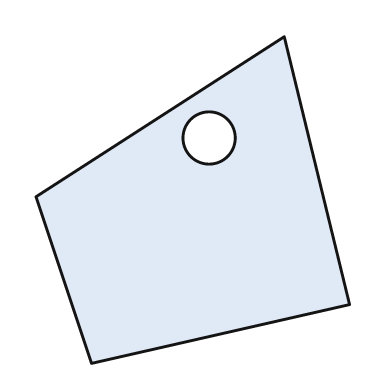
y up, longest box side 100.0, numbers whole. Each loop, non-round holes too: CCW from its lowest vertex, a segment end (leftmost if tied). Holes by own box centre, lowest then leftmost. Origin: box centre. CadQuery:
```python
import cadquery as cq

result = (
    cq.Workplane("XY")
    .moveTo(-31.0, -50.0)
    .lineTo(48.0, -32.0)
    .lineTo(28.0, 50.0)
    .lineTo(-48.0, 1.0)
    .close()
    .moveTo(5.0, 19.0)
    .circle(8.0)
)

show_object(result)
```